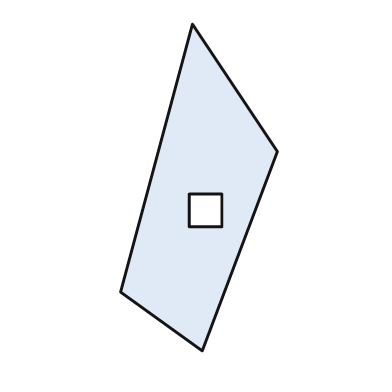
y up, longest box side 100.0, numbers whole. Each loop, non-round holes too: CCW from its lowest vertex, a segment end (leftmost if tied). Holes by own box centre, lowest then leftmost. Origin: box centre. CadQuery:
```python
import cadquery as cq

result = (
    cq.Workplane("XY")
    .moveTo(1.0, -50.0)
    .lineTo(24.0, 11.0)
    .lineTo(-2.0, 50.0)
    .lineTo(-24.0, -32.0)
    .close()
    .moveTo(-3.0, -12.0)
    .lineTo(7.0, -12.0)
    .lineTo(7.0, -2.0)
    .lineTo(-3.0, -2.0)
    .close()
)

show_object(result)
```